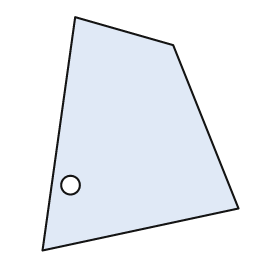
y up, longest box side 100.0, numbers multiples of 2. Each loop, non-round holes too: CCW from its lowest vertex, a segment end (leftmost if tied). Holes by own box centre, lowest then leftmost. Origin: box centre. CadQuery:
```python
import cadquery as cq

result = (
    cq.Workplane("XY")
    .moveTo(-42.0, -50.0)
    .lineTo(42.0, -32.0)
    .lineTo(14.0, 38.0)
    .lineTo(-28.0, 50.0)
    .close()
    .moveTo(-30.0, -22.0)
    .circle(4.0)
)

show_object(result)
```